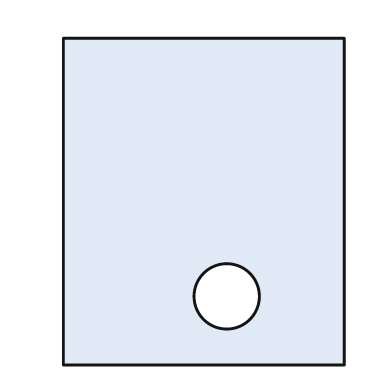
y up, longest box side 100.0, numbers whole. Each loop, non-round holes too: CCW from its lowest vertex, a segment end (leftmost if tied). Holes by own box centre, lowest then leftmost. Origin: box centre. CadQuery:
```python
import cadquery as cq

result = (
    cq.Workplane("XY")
    .moveTo(-43.0, -50.0)
    .lineTo(43.0, -50.0)
    .lineTo(43.0, 50.0)
    .lineTo(-43.0, 50.0)
    .close()
    .moveTo(7.0, -29.0)
    .circle(10.0)
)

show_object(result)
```